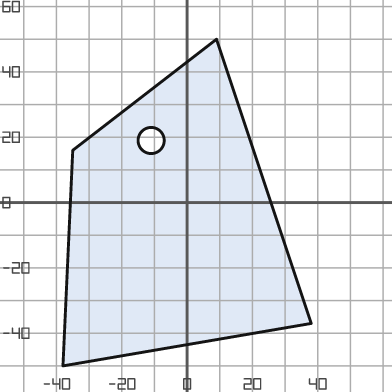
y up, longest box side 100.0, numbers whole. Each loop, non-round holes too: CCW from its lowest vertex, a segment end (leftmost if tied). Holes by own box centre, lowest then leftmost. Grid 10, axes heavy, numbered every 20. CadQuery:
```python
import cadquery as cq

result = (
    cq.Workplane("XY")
    .moveTo(-38.0, -50.0)
    .lineTo(38.0, -37.0)
    .lineTo(9.0, 50.0)
    .lineTo(-35.0, 16.0)
    .close()
    .moveTo(-11.0, 19.0)
    .circle(4.0)
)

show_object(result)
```